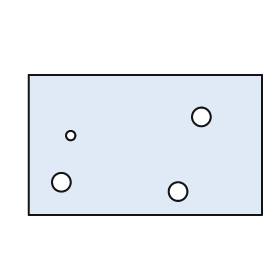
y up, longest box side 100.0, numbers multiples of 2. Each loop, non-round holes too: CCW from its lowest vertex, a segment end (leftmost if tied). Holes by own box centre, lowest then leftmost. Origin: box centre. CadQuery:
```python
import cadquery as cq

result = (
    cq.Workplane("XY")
    .moveTo(-50.0, -30.0)
    .lineTo(50.0, -30.0)
    .lineTo(50.0, 30.0)
    .lineTo(-50.0, 30.0)
    .close()
    .moveTo(14.0, -20.0)
    .circle(4.0)
    .moveTo(-36.0, -16.0)
    .circle(4.0)
    .moveTo(-32.0, 4.0)
    .circle(2.0)
    .moveTo(24.0, 12.0)
    .circle(4.0)
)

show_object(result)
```